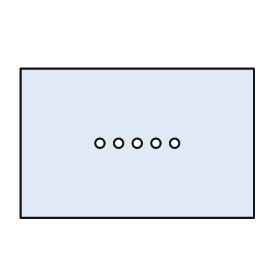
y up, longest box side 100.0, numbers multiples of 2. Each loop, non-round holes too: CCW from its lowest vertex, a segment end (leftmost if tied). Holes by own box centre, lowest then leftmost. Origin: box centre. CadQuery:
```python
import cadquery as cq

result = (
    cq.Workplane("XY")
    .moveTo(-50.0, -32.0)
    .lineTo(50.0, -32.0)
    .lineTo(50.0, 32.0)
    .lineTo(-50.0, 32.0)
    .close()
    .moveTo(-16.0, 0.0)
    .circle(2.0)
    .moveTo(-8.0, 0.0)
    .circle(2.0)
    .moveTo(0.0, 0.0)
    .circle(2.0)
    .moveTo(8.0, 0.0)
    .circle(2.0)
    .moveTo(16.0, 0.0)
    .circle(2.0)
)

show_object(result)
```